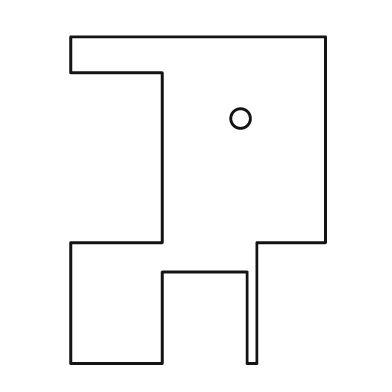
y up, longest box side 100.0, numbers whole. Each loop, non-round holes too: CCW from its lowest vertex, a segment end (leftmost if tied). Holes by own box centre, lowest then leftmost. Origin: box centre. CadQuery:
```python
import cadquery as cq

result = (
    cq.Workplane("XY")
    .moveTo(-39.0, -50.0)
    .lineTo(-11.0, -50.0)
    .lineTo(-11.0, -22.0)
    .lineTo(15.0, -22.0)
    .lineTo(15.0, -50.0)
    .lineTo(18.0, -50.0)
    .lineTo(18.0, -13.0)
    .lineTo(39.0, -13.0)
    .lineTo(39.0, 50.0)
    .lineTo(-39.0, 50.0)
    .lineTo(-39.0, 39.0)
    .lineTo(-11.0, 39.0)
    .lineTo(-11.0, -13.0)
    .lineTo(-39.0, -13.0)
    .close()
    .moveTo(13.0, 25.0)
    .circle(3.0)
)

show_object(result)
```